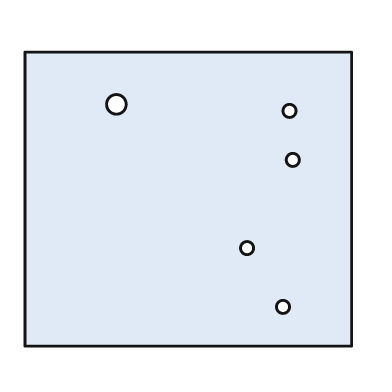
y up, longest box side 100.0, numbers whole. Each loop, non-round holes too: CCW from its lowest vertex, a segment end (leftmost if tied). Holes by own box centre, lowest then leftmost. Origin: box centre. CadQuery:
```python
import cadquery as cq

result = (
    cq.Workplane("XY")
    .moveTo(-50.0, -45.0)
    .lineTo(50.0, -45.0)
    .lineTo(50.0, 45.0)
    .lineTo(-50.0, 45.0)
    .close()
    .moveTo(29.0, -33.0)
    .circle(2.0)
    .moveTo(18.0, -15.0)
    .circle(2.0)
    .moveTo(32.0, 12.0)
    .circle(2.0)
    .moveTo(31.0, 27.0)
    .circle(2.0)
    .moveTo(-22.0, 29.0)
    .circle(3.0)
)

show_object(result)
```